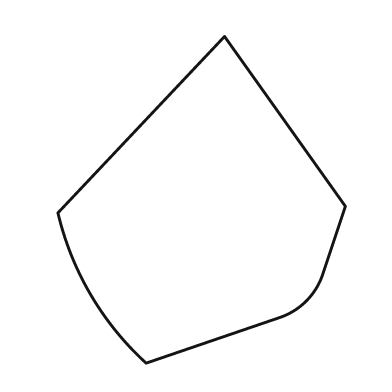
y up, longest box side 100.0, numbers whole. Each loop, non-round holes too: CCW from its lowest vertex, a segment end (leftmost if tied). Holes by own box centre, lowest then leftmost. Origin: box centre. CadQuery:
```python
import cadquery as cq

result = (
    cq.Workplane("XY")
    .moveTo(-17.0, -50.0)
    .lineTo(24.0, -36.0)
    .threePointArc((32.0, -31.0), (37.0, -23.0))
    .lineTo(44.0, -2.0)
    .lineTo(7.0, 50.0)
    .lineTo(-44.0, -4.0)
    .threePointArc((-34.0, -29.0), (-17.0, -50.0))
    .close()
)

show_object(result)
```